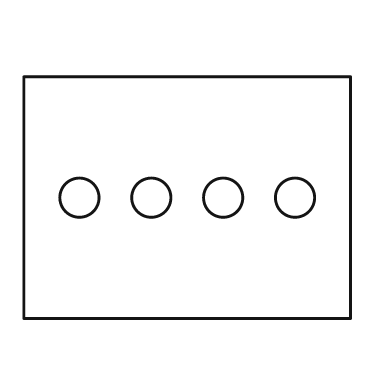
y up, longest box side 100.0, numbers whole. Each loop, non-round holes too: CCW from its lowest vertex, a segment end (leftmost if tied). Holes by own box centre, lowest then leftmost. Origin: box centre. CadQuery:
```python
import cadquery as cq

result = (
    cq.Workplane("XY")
    .moveTo(-50.0, -37.0)
    .lineTo(50.0, -37.0)
    .lineTo(50.0, 37.0)
    .lineTo(-50.0, 37.0)
    .close()
    .moveTo(-33.0, 0.0)
    .circle(6.0)
    .moveTo(-11.0, 0.0)
    .circle(6.0)
    .moveTo(11.0, 0.0)
    .circle(6.0)
    .moveTo(33.0, 0.0)
    .circle(6.0)
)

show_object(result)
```